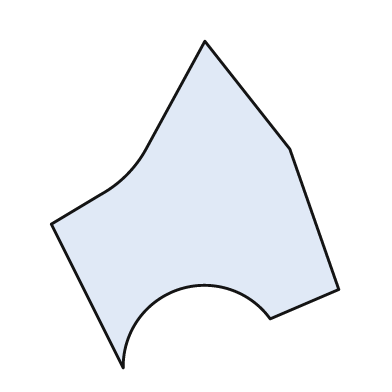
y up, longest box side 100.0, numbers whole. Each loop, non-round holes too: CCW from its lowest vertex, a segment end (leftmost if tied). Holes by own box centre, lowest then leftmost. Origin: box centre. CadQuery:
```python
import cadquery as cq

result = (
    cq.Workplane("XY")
    .moveTo(-22.0, -50.0)
    .threePointArc((-5.0, -26.0), (23.0, -35.0))
    .lineTo(44.0, -26.0)
    .lineTo(29.0, 17.0)
    .lineTo(3.0, 50.0)
    .lineTo(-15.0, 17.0)
    .threePointArc((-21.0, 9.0), (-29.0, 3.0))
    .lineTo(-44.0, -6.0)
    .close()
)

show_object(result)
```